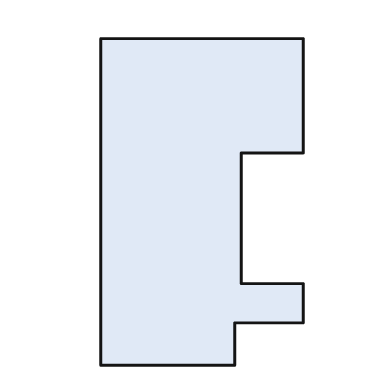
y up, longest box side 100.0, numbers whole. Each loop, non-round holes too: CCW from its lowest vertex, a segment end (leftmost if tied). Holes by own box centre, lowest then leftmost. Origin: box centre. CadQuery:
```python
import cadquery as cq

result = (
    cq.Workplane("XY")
    .moveTo(-31.0, -50.0)
    .lineTo(10.0, -50.0)
    .lineTo(10.0, -37.0)
    .lineTo(31.0, -37.0)
    .lineTo(31.0, -25.0)
    .lineTo(12.0, -25.0)
    .lineTo(12.0, 15.0)
    .lineTo(31.0, 15.0)
    .lineTo(31.0, 50.0)
    .lineTo(-31.0, 50.0)
    .close()
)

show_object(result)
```